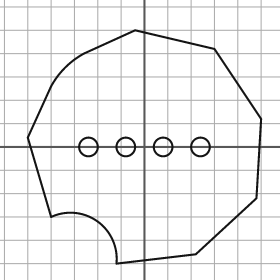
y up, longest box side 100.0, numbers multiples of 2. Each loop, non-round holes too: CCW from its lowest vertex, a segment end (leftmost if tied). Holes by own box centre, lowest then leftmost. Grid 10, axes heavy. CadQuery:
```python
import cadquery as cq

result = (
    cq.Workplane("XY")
    .moveTo(-12.0, -50.0)
    .lineTo(22.0, -46.0)
    .lineTo(48.0, -22.0)
    .lineTo(50.0, 12.0)
    .lineTo(30.0, 42.0)
    .lineTo(-4.0, 50.0)
    .lineTo(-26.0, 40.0)
    .threePointArc((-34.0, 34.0), (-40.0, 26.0))
    .lineTo(-50.0, 4.0)
    .lineTo(-40.0, -30.0)
    .threePointArc((-20.0, -32.0), (-12.0, -50.0))
    .close()
    .moveTo(-24.0, 0.0)
    .circle(4.0)
    .moveTo(-8.0, 0.0)
    .circle(4.0)
    .moveTo(8.0, 0.0)
    .circle(4.0)
    .moveTo(24.0, 0.0)
    .circle(4.0)
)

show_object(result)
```